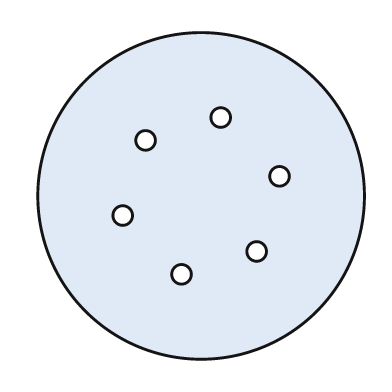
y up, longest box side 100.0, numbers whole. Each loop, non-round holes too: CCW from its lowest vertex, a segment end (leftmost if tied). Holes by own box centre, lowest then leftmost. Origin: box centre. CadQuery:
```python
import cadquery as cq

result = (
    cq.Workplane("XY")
    .moveTo(0.0, 0.0)
    .circle(50.0)
    .moveTo(-6.0, -24.0)
    .circle(3.0)
    .moveTo(17.0, -17.0)
    .circle(3.0)
    .moveTo(-24.0, -6.0)
    .circle(3.0)
    .moveTo(24.0, 6.0)
    .circle(3.0)
    .moveTo(-17.0, 17.0)
    .circle(3.0)
    .moveTo(6.0, 24.0)
    .circle(3.0)
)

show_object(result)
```